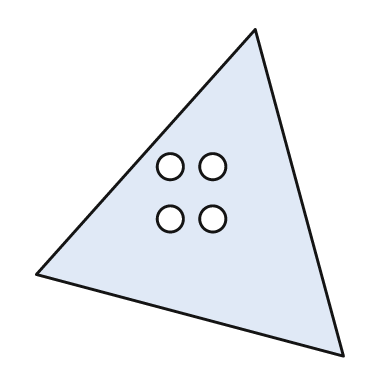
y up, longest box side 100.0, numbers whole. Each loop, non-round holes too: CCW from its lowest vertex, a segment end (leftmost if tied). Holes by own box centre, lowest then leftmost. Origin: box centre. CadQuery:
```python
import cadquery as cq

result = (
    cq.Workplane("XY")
    .moveTo(47.0, -50.0)
    .lineTo(20.0, 50.0)
    .lineTo(-47.0, -25.0)
    .close()
    .moveTo(-6.0, -8.0)
    .circle(4.0)
    .moveTo(7.0, -8.0)
    .circle(4.0)
    .moveTo(-6.0, 8.0)
    .circle(4.0)
    .moveTo(7.0, 8.0)
    .circle(4.0)
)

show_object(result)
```